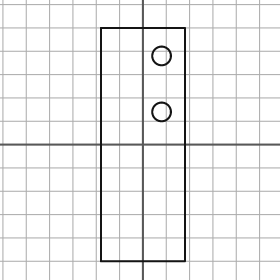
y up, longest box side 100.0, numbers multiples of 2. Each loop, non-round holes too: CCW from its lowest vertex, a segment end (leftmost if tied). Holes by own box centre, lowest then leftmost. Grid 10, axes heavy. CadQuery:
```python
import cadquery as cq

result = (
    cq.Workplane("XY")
    .moveTo(-18.0, -50.0)
    .lineTo(18.0, -50.0)
    .lineTo(18.0, 50.0)
    .lineTo(-18.0, 50.0)
    .close()
    .moveTo(8.0, 14.0)
    .circle(4.0)
    .moveTo(8.0, 38.0)
    .circle(4.0)
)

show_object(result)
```